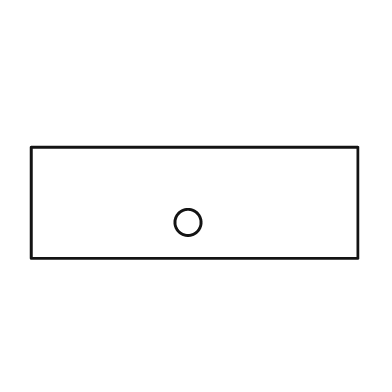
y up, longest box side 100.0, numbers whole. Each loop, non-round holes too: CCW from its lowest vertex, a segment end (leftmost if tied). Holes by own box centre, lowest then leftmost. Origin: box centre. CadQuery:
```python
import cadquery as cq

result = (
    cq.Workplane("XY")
    .moveTo(-50.0, -17.0)
    .lineTo(50.0, -17.0)
    .lineTo(50.0, 17.0)
    .lineTo(-50.0, 17.0)
    .close()
    .moveTo(-2.0, -6.0)
    .circle(4.0)
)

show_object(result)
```